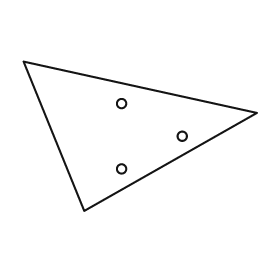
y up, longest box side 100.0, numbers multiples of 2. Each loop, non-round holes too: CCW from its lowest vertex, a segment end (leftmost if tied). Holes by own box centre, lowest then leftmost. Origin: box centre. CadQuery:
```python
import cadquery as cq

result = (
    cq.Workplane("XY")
    .moveTo(-24.0, -32.0)
    .lineTo(50.0, 10.0)
    .lineTo(-50.0, 32.0)
    .close()
    .moveTo(-8.0, -14.0)
    .circle(2.0)
    .moveTo(18.0, 0.0)
    .circle(2.0)
    .moveTo(-8.0, 14.0)
    .circle(2.0)
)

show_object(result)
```